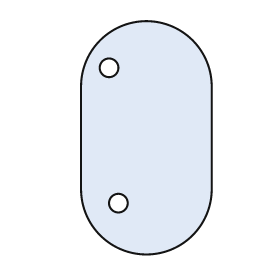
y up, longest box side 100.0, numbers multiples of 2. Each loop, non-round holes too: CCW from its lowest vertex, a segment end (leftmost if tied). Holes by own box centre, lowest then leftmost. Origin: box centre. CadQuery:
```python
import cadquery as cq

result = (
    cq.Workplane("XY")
    .moveTo(-28.0, -22.0)
    .threePointArc((0.0, -50.0), (28.0, -22.0))
    .lineTo(28.0, 22.0)
    .threePointArc((0.0, 50.0), (-28.0, 22.0))
    .close()
    .moveTo(-12.0, -28.0)
    .circle(4.0)
    .moveTo(-16.0, 30.0)
    .circle(4.0)
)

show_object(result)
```